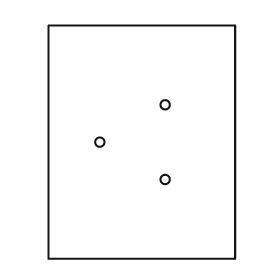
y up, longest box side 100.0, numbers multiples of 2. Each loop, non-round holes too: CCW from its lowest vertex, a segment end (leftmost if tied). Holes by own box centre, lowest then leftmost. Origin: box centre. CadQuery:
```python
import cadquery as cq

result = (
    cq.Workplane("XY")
    .moveTo(-40.0, -50.0)
    .lineTo(40.0, -50.0)
    .lineTo(40.0, 50.0)
    .lineTo(-40.0, 50.0)
    .close()
    .moveTo(10.0, -16.0)
    .circle(2.0)
    .moveTo(-18.0, 0.0)
    .circle(2.0)
    .moveTo(10.0, 16.0)
    .circle(2.0)
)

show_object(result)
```